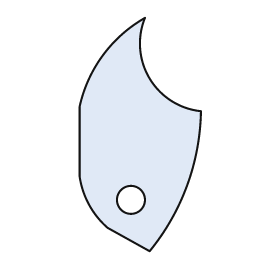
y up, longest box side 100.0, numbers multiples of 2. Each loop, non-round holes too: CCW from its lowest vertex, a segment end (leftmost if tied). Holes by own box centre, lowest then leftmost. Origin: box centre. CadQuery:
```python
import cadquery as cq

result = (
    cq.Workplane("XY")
    .moveTo(4.0, -50.0)
    .threePointArc((20.0, -22.0), (26.0, 10.0))
    .threePointArc((4.0, 24.0), (2.0, 50.0))
    .threePointArc((-16.0, 34.0), (-26.0, 12.0))
    .lineTo(-26.0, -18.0)
    .threePointArc((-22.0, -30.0), (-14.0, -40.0))
    .close()
    .moveTo(-4.0, -28.0)
    .circle(6.0)
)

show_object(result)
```